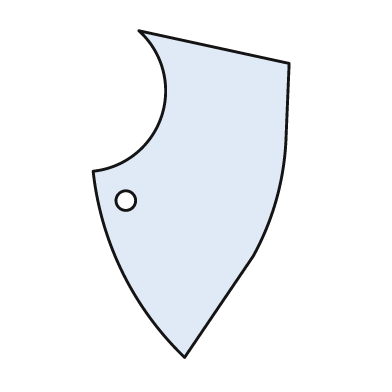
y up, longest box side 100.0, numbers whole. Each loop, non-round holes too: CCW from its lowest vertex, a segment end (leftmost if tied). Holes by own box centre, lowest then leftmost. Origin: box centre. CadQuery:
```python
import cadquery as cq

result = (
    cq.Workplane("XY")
    .moveTo(-2.0, -50.0)
    .lineTo(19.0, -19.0)
    .threePointArc((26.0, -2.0), (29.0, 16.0))
    .lineTo(30.0, 40.0)
    .lineTo(-16.0, 50.0)
    .threePointArc((-9.0, 24.0), (-30.0, 7.0))
    .threePointArc((-21.0, -24.0), (-2.0, -50.0))
    .close()
    .moveTo(-20.0, -2.0)
    .circle(3.0)
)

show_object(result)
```